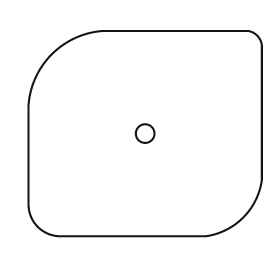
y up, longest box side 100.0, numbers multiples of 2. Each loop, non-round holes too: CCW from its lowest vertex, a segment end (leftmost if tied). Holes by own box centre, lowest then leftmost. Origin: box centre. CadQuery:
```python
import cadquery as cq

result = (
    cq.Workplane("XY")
    .moveTo(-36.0, -44.0)
    .lineTo(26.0, -44.0)
    .threePointArc((42.0, -36.0), (50.0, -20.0))
    .lineTo(50.0, 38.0)
    .threePointArc((48.0, 42.0), (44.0, 44.0))
    .lineTo(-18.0, 44.0)
    .threePointArc((-40.0, 34.0), (-50.0, 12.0))
    .lineTo(-50.0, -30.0)
    .threePointArc((-46.0, -40.0), (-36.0, -44.0))
    .close()
    .moveTo(0.0, 0.0)
    .circle(4.0)
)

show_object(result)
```